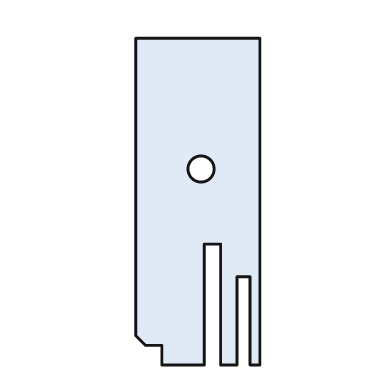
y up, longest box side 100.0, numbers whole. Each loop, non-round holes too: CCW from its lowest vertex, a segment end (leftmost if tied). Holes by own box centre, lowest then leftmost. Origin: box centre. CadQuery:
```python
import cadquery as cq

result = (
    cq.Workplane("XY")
    .moveTo(-11.0, -50.0)
    .lineTo(2.0, -50.0)
    .lineTo(2.0, -13.0)
    .lineTo(7.0, -13.0)
    .lineTo(7.0, -50.0)
    .lineTo(12.0, -50.0)
    .lineTo(12.0, -23.0)
    .lineTo(16.0, -23.0)
    .lineTo(16.0, -50.0)
    .lineTo(19.0, -50.0)
    .lineTo(19.0, 50.0)
    .lineTo(-19.0, 50.0)
    .lineTo(-19.0, -41.0)
    .lineTo(-16.0, -44.0)
    .lineTo(-11.0, -44.0)
    .close()
    .moveTo(1.0, 10.0)
    .circle(4.0)
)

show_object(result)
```